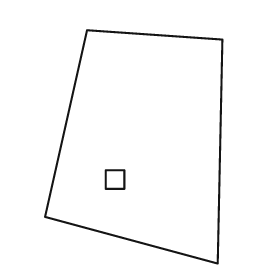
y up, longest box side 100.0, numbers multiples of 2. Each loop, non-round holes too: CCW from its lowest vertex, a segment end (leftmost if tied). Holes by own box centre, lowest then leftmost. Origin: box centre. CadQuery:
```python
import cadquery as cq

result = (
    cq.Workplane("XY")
    .moveTo(36.0, -50.0)
    .lineTo(38.0, 46.0)
    .lineTo(-20.0, 50.0)
    .lineTo(-38.0, -30.0)
    .close()
    .moveTo(-12.0, -18.0)
    .lineTo(-4.0, -18.0)
    .lineTo(-4.0, -10.0)
    .lineTo(-12.0, -10.0)
    .close()
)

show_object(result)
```